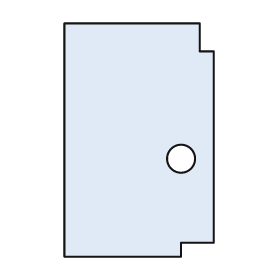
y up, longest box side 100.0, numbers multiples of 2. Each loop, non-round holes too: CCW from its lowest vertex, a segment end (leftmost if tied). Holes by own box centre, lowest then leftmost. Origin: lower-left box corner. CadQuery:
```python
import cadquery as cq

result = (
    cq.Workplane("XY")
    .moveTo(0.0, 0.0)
    .lineTo(50.0, 0.0)
    .lineTo(50.0, 6.0)
    .lineTo(64.0, 6.0)
    .lineTo(64.0, 88.0)
    .lineTo(58.0, 88.0)
    .lineTo(58.0, 100.0)
    .lineTo(0.0, 100.0)
    .close()
    .moveTo(50.0, 42.0)
    .circle(6.0)
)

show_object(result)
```